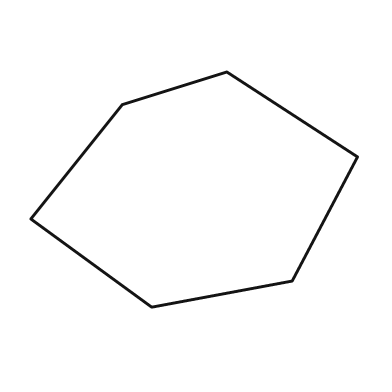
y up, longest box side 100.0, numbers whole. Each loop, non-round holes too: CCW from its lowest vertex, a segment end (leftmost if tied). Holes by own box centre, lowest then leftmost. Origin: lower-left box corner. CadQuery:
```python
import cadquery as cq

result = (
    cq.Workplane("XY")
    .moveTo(37.0, 0.0)
    .lineTo(80.0, 8.0)
    .lineTo(100.0, 46.0)
    .lineTo(60.0, 72.0)
    .lineTo(28.0, 62.0)
    .lineTo(0.0, 27.0)
    .close()
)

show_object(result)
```